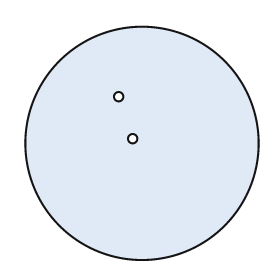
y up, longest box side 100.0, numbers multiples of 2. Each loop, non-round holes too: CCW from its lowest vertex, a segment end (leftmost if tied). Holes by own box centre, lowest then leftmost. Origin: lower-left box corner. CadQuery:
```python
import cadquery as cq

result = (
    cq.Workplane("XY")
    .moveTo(50.0, 50.0)
    .circle(50.0)
    .moveTo(46.0, 52.0)
    .circle(2.0)
    .moveTo(40.0, 70.0)
    .circle(2.0)
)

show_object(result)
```